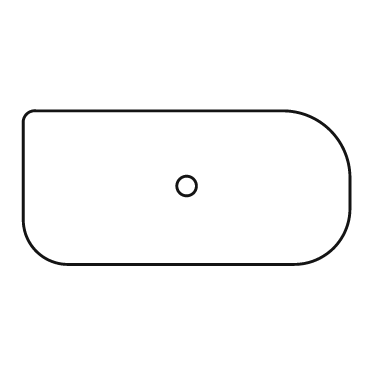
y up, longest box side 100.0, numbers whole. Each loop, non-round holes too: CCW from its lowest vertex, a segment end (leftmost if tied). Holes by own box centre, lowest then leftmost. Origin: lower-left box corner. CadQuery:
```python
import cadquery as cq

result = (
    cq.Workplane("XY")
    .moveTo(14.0, 0.0)
    .lineTo(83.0, 0.0)
    .threePointArc((95.0, 5.0), (100.0, 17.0))
    .lineTo(100.0, 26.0)
    .threePointArc((94.0, 41.0), (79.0, 47.0))
    .lineTo(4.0, 47.0)
    .threePointArc((1.0, 46.0), (0.0, 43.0))
    .lineTo(0.0, 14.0)
    .threePointArc((4.0, 4.0), (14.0, 0.0))
    .close()
    .moveTo(50.0, 24.0)
    .circle(3.0)
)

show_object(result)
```